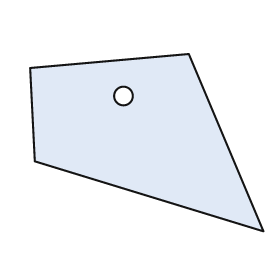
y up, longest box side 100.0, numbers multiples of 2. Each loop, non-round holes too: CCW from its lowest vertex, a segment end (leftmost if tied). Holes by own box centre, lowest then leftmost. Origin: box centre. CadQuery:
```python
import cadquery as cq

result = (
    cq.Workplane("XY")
    .moveTo(50.0, -38.0)
    .lineTo(18.0, 38.0)
    .lineTo(-50.0, 32.0)
    .lineTo(-48.0, -8.0)
    .close()
    .moveTo(-10.0, 20.0)
    .circle(4.0)
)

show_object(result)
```